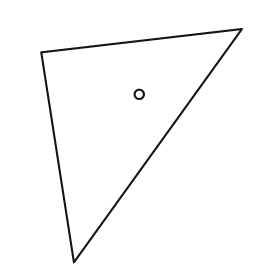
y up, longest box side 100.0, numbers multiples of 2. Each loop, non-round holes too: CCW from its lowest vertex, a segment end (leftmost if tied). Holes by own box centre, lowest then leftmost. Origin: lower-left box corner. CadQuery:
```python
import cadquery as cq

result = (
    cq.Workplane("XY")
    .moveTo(14.0, 0.0)
    .lineTo(86.0, 100.0)
    .lineTo(0.0, 90.0)
    .close()
    .moveTo(42.0, 72.0)
    .circle(2.0)
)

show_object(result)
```